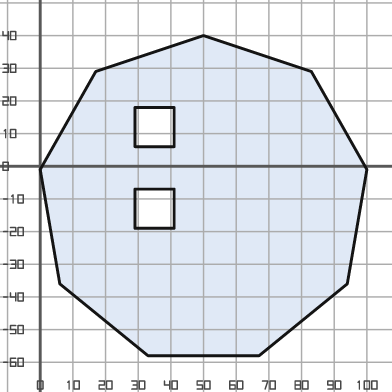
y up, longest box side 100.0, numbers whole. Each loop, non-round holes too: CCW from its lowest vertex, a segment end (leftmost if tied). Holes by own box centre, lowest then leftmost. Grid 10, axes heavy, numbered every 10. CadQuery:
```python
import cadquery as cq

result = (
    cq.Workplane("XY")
    .moveTo(33.0, -58.0)
    .lineTo(67.0, -58.0)
    .lineTo(94.0, -36.0)
    .lineTo(100.0, -1.0)
    .lineTo(83.0, 29.0)
    .lineTo(50.0, 40.0)
    .lineTo(17.0, 29.0)
    .lineTo(0.0, -1.0)
    .lineTo(6.0, -36.0)
    .close()
    .moveTo(29.0, -19.0)
    .lineTo(41.0, -19.0)
    .lineTo(41.0, -7.0)
    .lineTo(29.0, -7.0)
    .close()
    .moveTo(29.0, 6.0)
    .lineTo(41.0, 6.0)
    .lineTo(41.0, 18.0)
    .lineTo(29.0, 18.0)
    .close()
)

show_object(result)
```